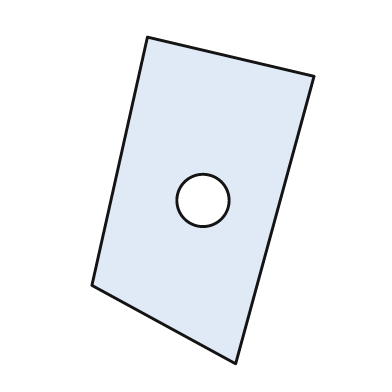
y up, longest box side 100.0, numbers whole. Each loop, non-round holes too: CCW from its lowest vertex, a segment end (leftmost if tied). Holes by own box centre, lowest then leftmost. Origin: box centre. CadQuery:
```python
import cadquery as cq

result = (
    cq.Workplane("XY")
    .moveTo(10.0, -50.0)
    .lineTo(34.0, 38.0)
    .lineTo(-17.0, 50.0)
    .lineTo(-34.0, -26.0)
    .close()
    .moveTo(0.0, 0.0)
    .circle(8.0)
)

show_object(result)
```